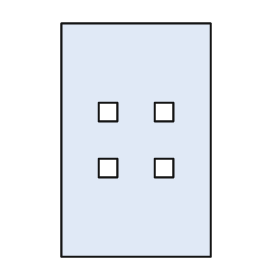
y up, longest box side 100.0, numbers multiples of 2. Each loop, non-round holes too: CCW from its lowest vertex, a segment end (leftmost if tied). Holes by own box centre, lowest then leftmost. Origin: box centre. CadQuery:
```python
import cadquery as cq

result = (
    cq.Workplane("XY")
    .moveTo(-32.0, -50.0)
    .lineTo(32.0, -50.0)
    .lineTo(32.0, 50.0)
    .lineTo(-32.0, 50.0)
    .close()
    .moveTo(-16.0, -16.0)
    .lineTo(-8.0, -16.0)
    .lineTo(-8.0, -8.0)
    .lineTo(-16.0, -8.0)
    .close()
    .moveTo(8.0, -16.0)
    .lineTo(16.0, -16.0)
    .lineTo(16.0, -8.0)
    .lineTo(8.0, -8.0)
    .close()
    .moveTo(-16.0, 8.0)
    .lineTo(-8.0, 8.0)
    .lineTo(-8.0, 16.0)
    .lineTo(-16.0, 16.0)
    .close()
    .moveTo(8.0, 8.0)
    .lineTo(16.0, 8.0)
    .lineTo(16.0, 16.0)
    .lineTo(8.0, 16.0)
    .close()
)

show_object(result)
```